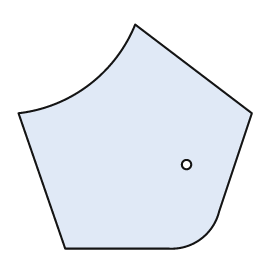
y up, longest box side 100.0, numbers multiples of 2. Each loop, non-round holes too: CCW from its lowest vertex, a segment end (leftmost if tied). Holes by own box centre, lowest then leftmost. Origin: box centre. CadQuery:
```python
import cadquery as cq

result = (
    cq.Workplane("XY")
    .moveTo(-30.0, -48.0)
    .lineTo(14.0, -48.0)
    .threePointArc((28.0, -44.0), (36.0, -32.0))
    .lineTo(50.0, 10.0)
    .lineTo(0.0, 48.0)
    .threePointArc((-20.0, 22.0), (-50.0, 10.0))
    .close()
    .moveTo(22.0, -12.0)
    .circle(2.0)
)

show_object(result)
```